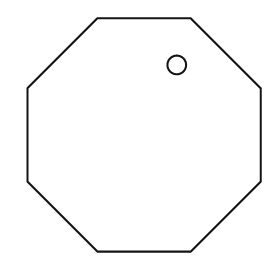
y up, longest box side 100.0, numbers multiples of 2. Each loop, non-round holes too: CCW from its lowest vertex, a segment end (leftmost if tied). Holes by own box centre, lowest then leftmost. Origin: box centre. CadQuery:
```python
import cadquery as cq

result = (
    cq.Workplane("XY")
    .moveTo(-20.0, -50.0)
    .lineTo(20.0, -50.0)
    .lineTo(50.0, -20.0)
    .lineTo(50.0, 20.0)
    .lineTo(20.0, 50.0)
    .lineTo(-20.0, 50.0)
    .lineTo(-50.0, 20.0)
    .lineTo(-50.0, -20.0)
    .close()
    .moveTo(14.0, 30.0)
    .circle(4.0)
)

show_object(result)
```